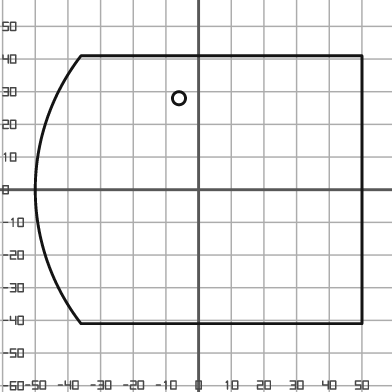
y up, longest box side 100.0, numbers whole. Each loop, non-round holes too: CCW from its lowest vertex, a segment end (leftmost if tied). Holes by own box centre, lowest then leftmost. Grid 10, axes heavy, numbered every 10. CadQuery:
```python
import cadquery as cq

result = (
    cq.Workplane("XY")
    .moveTo(-36.0, -41.0)
    .lineTo(50.0, -41.0)
    .lineTo(50.0, 41.0)
    .lineTo(-36.0, 41.0)
    .threePointArc((-50.0, 0.0), (-36.0, -41.0))
    .close()
    .moveTo(-6.0, 28.0)
    .circle(2.0)
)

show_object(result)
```